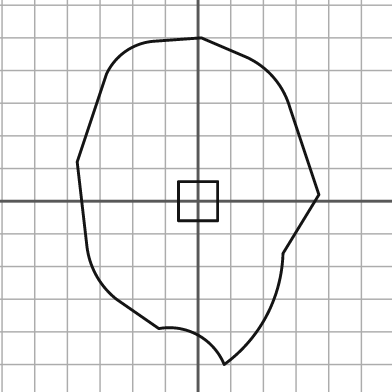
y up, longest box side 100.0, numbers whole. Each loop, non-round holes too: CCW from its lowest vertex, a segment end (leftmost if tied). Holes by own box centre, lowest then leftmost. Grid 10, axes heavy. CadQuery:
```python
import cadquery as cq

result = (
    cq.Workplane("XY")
    .moveTo(8.0, -50.0)
    .threePointArc((21.0, -35.0), (26.0, -16.0))
    .lineTo(37.0, 2.0)
    .lineTo(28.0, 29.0)
    .threePointArc((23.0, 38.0), (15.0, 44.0))
    .lineTo(1.0, 50.0)
    .lineTo(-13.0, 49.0)
    .threePointArc((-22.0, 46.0), (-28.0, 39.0))
    .lineTo(-37.0, 12.0)
    .lineTo(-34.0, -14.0)
    .threePointArc((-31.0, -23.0), (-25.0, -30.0))
    .lineTo(-12.0, -39.0)
    .threePointArc((0.0, -41.0), (8.0, -50.0))
    .close()
    .moveTo(-6.0, -6.0)
    .lineTo(6.0, -6.0)
    .lineTo(6.0, 6.0)
    .lineTo(-6.0, 6.0)
    .close()
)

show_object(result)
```